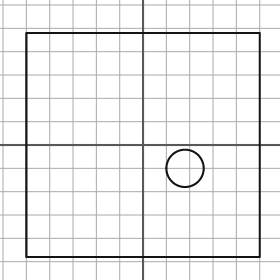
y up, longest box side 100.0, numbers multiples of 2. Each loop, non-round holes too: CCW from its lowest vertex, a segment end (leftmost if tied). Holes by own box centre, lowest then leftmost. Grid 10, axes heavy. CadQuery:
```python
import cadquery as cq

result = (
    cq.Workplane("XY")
    .moveTo(-50.0, -48.0)
    .lineTo(50.0, -48.0)
    .lineTo(50.0, 48.0)
    .lineTo(-50.0, 48.0)
    .close()
    .moveTo(18.0, -10.0)
    .circle(8.0)
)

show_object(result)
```